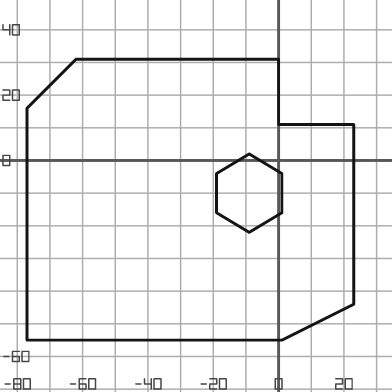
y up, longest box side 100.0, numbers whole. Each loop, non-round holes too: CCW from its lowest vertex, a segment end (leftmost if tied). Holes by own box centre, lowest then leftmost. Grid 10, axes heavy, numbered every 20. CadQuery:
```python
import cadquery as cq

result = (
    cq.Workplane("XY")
    .moveTo(-77.0, -55.0)
    .lineTo(1.0, -55.0)
    .lineTo(23.0, -44.0)
    .lineTo(23.0, 11.0)
    .lineTo(0.0, 11.0)
    .lineTo(0.0, 31.0)
    .lineTo(-62.0, 31.0)
    .lineTo(-77.0, 16.0)
    .close()
    .moveTo(-9.0, -22.0)
    .lineTo(1.0, -16.0)
    .lineTo(1.0, -4.0)
    .lineTo(-9.0, 2.0)
    .lineTo(-19.0, -4.0)
    .lineTo(-19.0, -16.0)
    .close()
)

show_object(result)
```